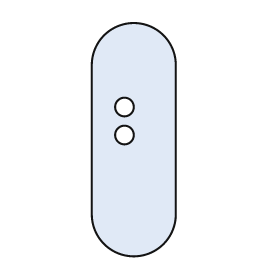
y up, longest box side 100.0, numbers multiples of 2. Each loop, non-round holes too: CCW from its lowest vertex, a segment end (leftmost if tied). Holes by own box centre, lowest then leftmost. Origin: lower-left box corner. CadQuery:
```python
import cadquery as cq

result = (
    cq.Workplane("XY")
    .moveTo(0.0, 18.0)
    .threePointArc((18.0, 0.0), (36.0, 18.0))
    .lineTo(36.0, 82.0)
    .threePointArc((18.0, 100.0), (0.0, 82.0))
    .close()
    .moveTo(14.0, 52.0)
    .circle(4.0)
    .moveTo(14.0, 64.0)
    .circle(4.0)
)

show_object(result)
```